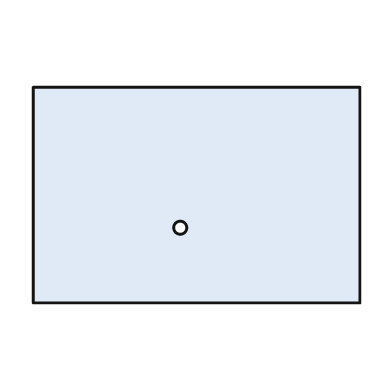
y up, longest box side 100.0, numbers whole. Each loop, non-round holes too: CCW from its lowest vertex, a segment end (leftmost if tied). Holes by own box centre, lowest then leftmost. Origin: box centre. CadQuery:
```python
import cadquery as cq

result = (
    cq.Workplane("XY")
    .moveTo(-50.0, -33.0)
    .lineTo(50.0, -33.0)
    .lineTo(50.0, 33.0)
    .lineTo(-50.0, 33.0)
    .close()
    .moveTo(-5.0, -10.0)
    .circle(2.0)
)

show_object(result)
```